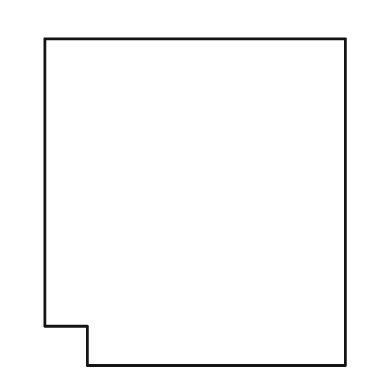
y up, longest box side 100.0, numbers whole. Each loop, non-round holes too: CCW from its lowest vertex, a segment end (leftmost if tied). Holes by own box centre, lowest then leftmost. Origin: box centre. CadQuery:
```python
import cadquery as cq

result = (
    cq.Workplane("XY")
    .moveTo(-33.0, -50.0)
    .lineTo(46.0, -50.0)
    .lineTo(46.0, 50.0)
    .lineTo(-46.0, 50.0)
    .lineTo(-46.0, -38.0)
    .lineTo(-33.0, -38.0)
    .close()
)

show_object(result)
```